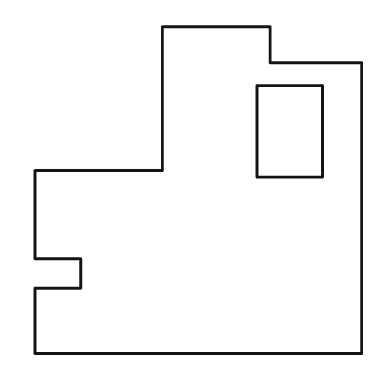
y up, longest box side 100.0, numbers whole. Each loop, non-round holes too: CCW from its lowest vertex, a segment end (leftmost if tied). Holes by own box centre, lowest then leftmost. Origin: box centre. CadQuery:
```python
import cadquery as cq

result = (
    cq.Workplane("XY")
    .moveTo(-50.0, -50.0)
    .lineTo(50.0, -50.0)
    .lineTo(50.0, 39.0)
    .lineTo(22.0, 39.0)
    .lineTo(22.0, 50.0)
    .lineTo(-11.0, 50.0)
    .lineTo(-11.0, 6.0)
    .lineTo(-50.0, 6.0)
    .lineTo(-50.0, -21.0)
    .lineTo(-36.0, -21.0)
    .lineTo(-36.0, -30.0)
    .lineTo(-50.0, -30.0)
    .close()
    .moveTo(18.0, 4.0)
    .lineTo(38.0, 4.0)
    .lineTo(38.0, 32.0)
    .lineTo(18.0, 32.0)
    .close()
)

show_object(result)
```